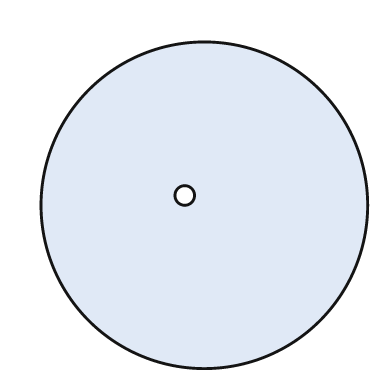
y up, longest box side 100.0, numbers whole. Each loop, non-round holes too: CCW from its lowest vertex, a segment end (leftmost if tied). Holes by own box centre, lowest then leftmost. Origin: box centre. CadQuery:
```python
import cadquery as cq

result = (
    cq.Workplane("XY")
    .moveTo(0.0, 0.0)
    .circle(50.0)
    .moveTo(-6.0, 3.0)
    .circle(3.0)
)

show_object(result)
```